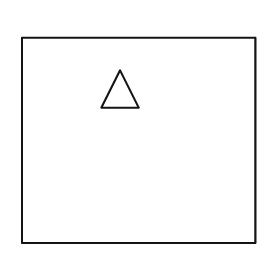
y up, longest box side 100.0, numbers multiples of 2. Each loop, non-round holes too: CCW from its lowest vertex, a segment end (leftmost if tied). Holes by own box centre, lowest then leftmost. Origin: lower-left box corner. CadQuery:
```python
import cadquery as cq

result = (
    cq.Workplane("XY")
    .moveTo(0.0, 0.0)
    .lineTo(100.0, 0.0)
    .lineTo(100.0, 88.0)
    .lineTo(0.0, 88.0)
    .close()
    .moveTo(34.0, 58.0)
    .lineTo(50.0, 58.0)
    .lineTo(42.0, 74.0)
    .close()
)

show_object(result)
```